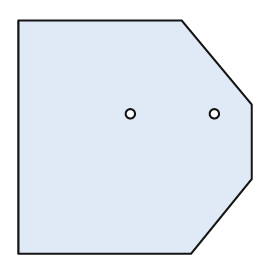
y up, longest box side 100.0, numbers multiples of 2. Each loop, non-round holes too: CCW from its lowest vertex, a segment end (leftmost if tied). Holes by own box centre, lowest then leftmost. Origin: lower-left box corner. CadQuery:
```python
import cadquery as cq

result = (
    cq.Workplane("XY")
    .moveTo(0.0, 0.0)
    .lineTo(74.0, 0.0)
    .lineTo(100.0, 32.0)
    .lineTo(100.0, 64.0)
    .lineTo(70.0, 100.0)
    .lineTo(0.0, 100.0)
    .close()
    .moveTo(48.0, 60.0)
    .circle(2.0)
    .moveTo(84.0, 60.0)
    .circle(2.0)
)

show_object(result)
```